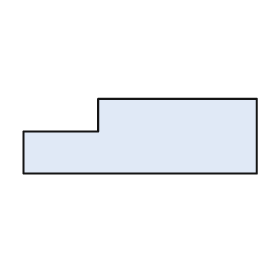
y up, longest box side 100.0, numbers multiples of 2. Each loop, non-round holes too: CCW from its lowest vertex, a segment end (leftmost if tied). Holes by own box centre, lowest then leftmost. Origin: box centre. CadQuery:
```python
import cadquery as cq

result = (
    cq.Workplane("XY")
    .moveTo(-50.0, -16.0)
    .lineTo(50.0, -16.0)
    .lineTo(50.0, 16.0)
    .lineTo(-18.0, 16.0)
    .lineTo(-18.0, 2.0)
    .lineTo(-50.0, 2.0)
    .close()
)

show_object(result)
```